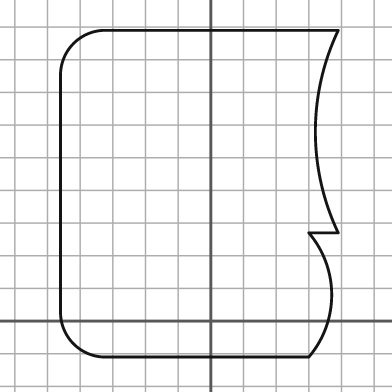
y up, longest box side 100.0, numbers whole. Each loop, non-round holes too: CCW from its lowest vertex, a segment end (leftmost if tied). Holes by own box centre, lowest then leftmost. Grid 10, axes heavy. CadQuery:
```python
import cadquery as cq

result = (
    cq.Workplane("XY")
    .moveTo(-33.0, -11.0)
    .lineTo(30.0, -11.0)
    .threePointArc((37.0, 8.0), (30.0, 27.0))
    .lineTo(39.0, 27.0)
    .threePointArc((32.0, 58.0), (39.0, 89.0))
    .lineTo(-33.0, 89.0)
    .threePointArc((-42.0, 85.0), (-46.0, 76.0))
    .lineTo(-46.0, 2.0)
    .threePointArc((-42.0, -7.0), (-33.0, -11.0))
    .close()
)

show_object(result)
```